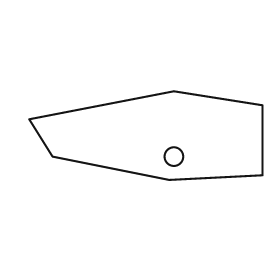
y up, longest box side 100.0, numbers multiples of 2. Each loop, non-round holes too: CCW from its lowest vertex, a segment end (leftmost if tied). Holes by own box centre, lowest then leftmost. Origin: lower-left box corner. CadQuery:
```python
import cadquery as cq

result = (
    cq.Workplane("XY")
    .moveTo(60.0, 0.0)
    .lineTo(100.0, 2.0)
    .lineTo(100.0, 32.0)
    .lineTo(62.0, 38.0)
    .lineTo(0.0, 26.0)
    .lineTo(10.0, 10.0)
    .close()
    .moveTo(62.0, 10.0)
    .circle(4.0)
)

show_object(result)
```